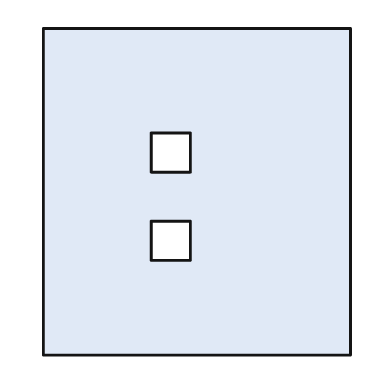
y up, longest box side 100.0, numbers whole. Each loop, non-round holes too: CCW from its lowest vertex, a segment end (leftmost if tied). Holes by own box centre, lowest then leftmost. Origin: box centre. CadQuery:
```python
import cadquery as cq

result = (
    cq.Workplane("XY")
    .moveTo(-47.0, -50.0)
    .lineTo(47.0, -50.0)
    .lineTo(47.0, 50.0)
    .lineTo(-47.0, 50.0)
    .close()
    .moveTo(-14.0, -21.0)
    .lineTo(-2.0, -21.0)
    .lineTo(-2.0, -9.0)
    .lineTo(-14.0, -9.0)
    .close()
    .moveTo(-14.0, 6.0)
    .lineTo(-2.0, 6.0)
    .lineTo(-2.0, 18.0)
    .lineTo(-14.0, 18.0)
    .close()
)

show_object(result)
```